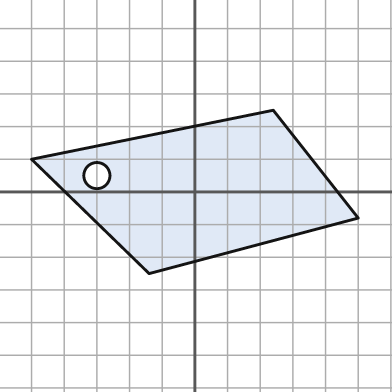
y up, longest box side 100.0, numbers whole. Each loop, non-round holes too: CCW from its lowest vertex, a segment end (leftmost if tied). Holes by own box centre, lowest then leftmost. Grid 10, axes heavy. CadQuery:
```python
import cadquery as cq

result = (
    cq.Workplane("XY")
    .moveTo(-14.0, -25.0)
    .lineTo(50.0, -8.0)
    .lineTo(24.0, 25.0)
    .lineTo(-50.0, 10.0)
    .close()
    .moveTo(-30.0, 5.0)
    .circle(4.0)
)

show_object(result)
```